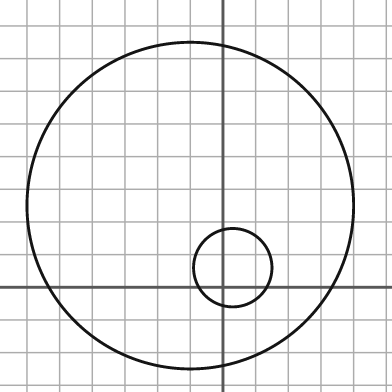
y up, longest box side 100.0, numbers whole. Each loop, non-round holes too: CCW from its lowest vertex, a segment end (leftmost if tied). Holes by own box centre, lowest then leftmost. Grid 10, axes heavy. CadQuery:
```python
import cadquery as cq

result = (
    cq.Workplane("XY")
    .moveTo(-10.0, 25.0)
    .circle(50.0)
    .moveTo(3.0, 6.0)
    .circle(12.0)
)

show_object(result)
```